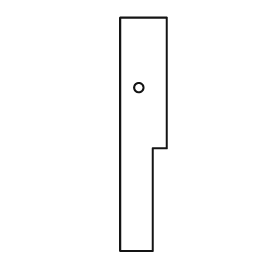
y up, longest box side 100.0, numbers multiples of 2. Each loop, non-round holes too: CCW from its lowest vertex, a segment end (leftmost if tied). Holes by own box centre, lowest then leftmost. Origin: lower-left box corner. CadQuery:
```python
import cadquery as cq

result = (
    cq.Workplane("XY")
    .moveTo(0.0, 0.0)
    .lineTo(14.0, 0.0)
    .lineTo(14.0, 44.0)
    .lineTo(20.0, 44.0)
    .lineTo(20.0, 100.0)
    .lineTo(0.0, 100.0)
    .close()
    .moveTo(8.0, 70.0)
    .circle(2.0)
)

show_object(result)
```